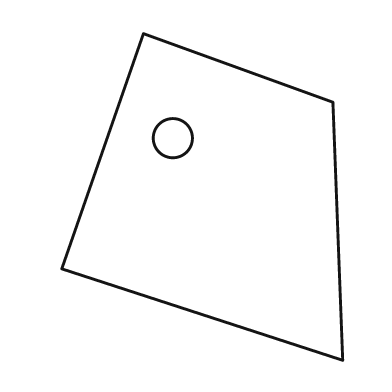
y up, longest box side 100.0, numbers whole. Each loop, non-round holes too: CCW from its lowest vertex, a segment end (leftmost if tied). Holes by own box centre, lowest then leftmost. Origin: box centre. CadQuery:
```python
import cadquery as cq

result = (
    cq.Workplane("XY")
    .moveTo(43.0, -50.0)
    .lineTo(40.0, 29.0)
    .lineTo(-18.0, 50.0)
    .lineTo(-43.0, -22.0)
    .close()
    .moveTo(-9.0, 18.0)
    .circle(6.0)
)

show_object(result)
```